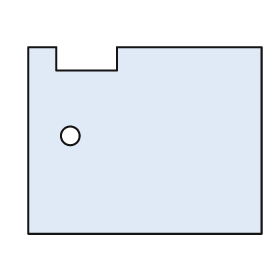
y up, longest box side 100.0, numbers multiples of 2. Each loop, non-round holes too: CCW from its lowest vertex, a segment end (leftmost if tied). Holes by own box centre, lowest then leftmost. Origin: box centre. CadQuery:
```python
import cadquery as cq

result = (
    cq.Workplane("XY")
    .moveTo(-50.0, -40.0)
    .lineTo(50.0, -40.0)
    .lineTo(50.0, 40.0)
    .lineTo(-12.0, 40.0)
    .lineTo(-12.0, 30.0)
    .lineTo(-38.0, 30.0)
    .lineTo(-38.0, 40.0)
    .lineTo(-50.0, 40.0)
    .close()
    .moveTo(-32.0, 2.0)
    .circle(4.0)
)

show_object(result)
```